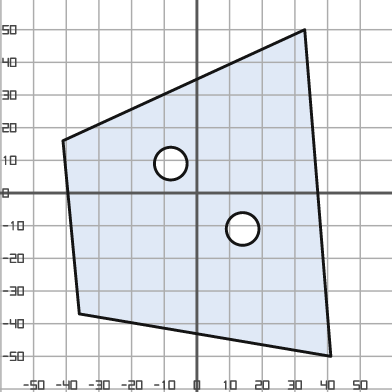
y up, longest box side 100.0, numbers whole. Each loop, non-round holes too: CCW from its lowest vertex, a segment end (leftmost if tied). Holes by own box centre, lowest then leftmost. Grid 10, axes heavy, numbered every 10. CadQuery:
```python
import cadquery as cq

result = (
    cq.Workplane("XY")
    .moveTo(41.0, -50.0)
    .lineTo(33.0, 50.0)
    .lineTo(-41.0, 16.0)
    .lineTo(-36.0, -37.0)
    .close()
    .moveTo(14.0, -11.0)
    .circle(5.0)
    .moveTo(-8.0, 9.0)
    .circle(5.0)
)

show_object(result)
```